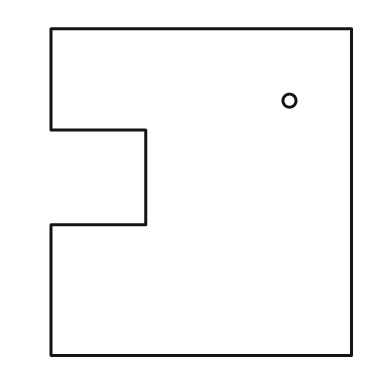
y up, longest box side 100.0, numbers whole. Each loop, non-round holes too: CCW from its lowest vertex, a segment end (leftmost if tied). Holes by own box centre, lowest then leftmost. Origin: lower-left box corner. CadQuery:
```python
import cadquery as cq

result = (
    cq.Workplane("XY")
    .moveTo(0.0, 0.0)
    .lineTo(92.0, 0.0)
    .lineTo(92.0, 100.0)
    .lineTo(0.0, 100.0)
    .lineTo(0.0, 69.0)
    .lineTo(29.0, 69.0)
    .lineTo(29.0, 40.0)
    .lineTo(0.0, 40.0)
    .close()
    .moveTo(73.0, 78.0)
    .circle(2.0)
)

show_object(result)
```